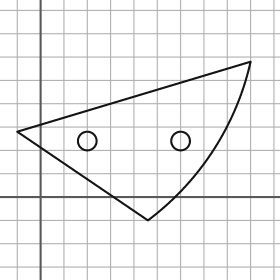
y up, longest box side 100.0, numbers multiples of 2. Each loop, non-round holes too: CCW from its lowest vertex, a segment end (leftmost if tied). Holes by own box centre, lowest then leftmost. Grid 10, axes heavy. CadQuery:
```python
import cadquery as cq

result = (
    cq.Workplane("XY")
    .moveTo(46.0, -10.0)
    .threePointArc((74.0, 20.0), (90.0, 58.0))
    .lineTo(-10.0, 28.0)
    .close()
    .moveTo(20.0, 24.0)
    .circle(4.0)
    .moveTo(60.0, 24.0)
    .circle(4.0)
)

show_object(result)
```